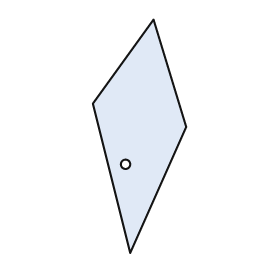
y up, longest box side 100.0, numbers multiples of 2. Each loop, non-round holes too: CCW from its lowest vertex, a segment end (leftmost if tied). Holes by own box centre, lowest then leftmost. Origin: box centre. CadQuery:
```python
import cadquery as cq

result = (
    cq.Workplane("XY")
    .moveTo(-4.0, -50.0)
    .lineTo(20.0, 4.0)
    .lineTo(6.0, 50.0)
    .lineTo(-20.0, 14.0)
    .close()
    .moveTo(-6.0, -12.0)
    .circle(2.0)
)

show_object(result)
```